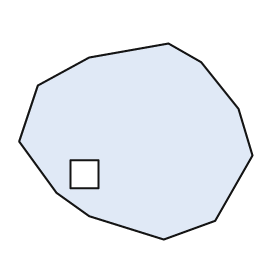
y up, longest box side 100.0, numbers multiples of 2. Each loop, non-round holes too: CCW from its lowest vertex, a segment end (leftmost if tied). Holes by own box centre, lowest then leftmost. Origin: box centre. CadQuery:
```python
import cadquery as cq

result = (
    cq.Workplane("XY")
    .moveTo(12.0, -42.0)
    .lineTo(34.0, -34.0)
    .lineTo(50.0, -6.0)
    .lineTo(44.0, 14.0)
    .lineTo(28.0, 34.0)
    .lineTo(14.0, 42.0)
    .lineTo(-20.0, 36.0)
    .lineTo(-42.0, 24.0)
    .lineTo(-50.0, 0.0)
    .lineTo(-34.0, -22.0)
    .lineTo(-20.0, -32.0)
    .close()
    .moveTo(-28.0, -20.0)
    .lineTo(-16.0, -20.0)
    .lineTo(-16.0, -8.0)
    .lineTo(-28.0, -8.0)
    .close()
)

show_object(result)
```